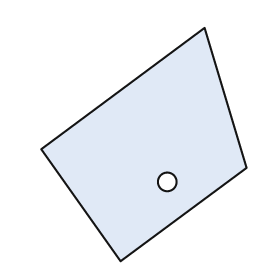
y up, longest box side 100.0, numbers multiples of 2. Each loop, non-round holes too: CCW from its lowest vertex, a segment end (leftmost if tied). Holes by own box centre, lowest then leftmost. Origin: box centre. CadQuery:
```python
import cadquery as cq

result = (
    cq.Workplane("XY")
    .moveTo(-10.0, -50.0)
    .lineTo(44.0, -10.0)
    .lineTo(26.0, 50.0)
    .lineTo(-44.0, -2.0)
    .close()
    .moveTo(10.0, -16.0)
    .circle(4.0)
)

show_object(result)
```